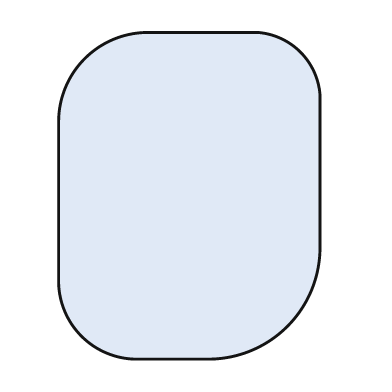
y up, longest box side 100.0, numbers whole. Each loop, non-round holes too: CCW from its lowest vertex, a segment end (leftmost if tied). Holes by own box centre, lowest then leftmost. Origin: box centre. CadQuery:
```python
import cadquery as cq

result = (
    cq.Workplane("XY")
    .moveTo(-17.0, -50.0)
    .lineTo(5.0, -50.0)
    .threePointArc((30.0, -40.0), (40.0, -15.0))
    .lineTo(40.0, 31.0)
    .threePointArc((34.0, 44.0), (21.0, 50.0))
    .lineTo(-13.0, 50.0)
    .threePointArc((-32.0, 42.0), (-40.0, 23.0))
    .lineTo(-40.0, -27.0)
    .threePointArc((-33.0, -43.0), (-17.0, -50.0))
    .close()
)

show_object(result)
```